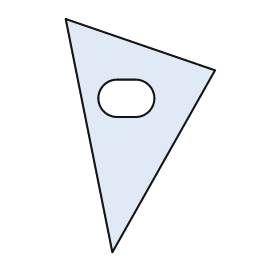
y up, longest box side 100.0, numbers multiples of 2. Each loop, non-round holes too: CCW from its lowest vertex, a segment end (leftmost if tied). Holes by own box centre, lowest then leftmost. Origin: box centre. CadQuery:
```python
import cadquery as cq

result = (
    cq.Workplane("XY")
    .moveTo(-12.0, -50.0)
    .lineTo(32.0, 28.0)
    .lineTo(-32.0, 50.0)
    .close()
    .moveTo(-10.0, 8.0)
    .lineTo(-2.0, 8.0)
    .threePointArc((6.0, 16.0), (-2.0, 24.0))
    .lineTo(-10.0, 24.0)
    .threePointArc((-18.0, 16.0), (-10.0, 8.0))
    .close()
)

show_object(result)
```